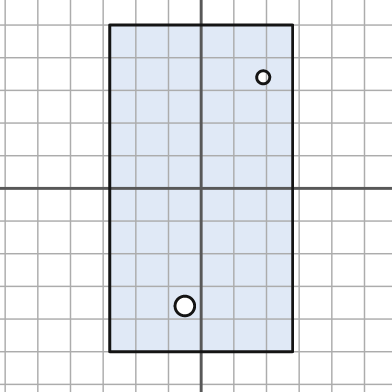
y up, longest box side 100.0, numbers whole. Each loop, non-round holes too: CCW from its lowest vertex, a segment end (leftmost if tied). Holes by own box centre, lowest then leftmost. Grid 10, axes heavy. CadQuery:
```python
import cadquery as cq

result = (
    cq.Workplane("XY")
    .moveTo(-28.0, -50.0)
    .lineTo(28.0, -50.0)
    .lineTo(28.0, 50.0)
    .lineTo(-28.0, 50.0)
    .close()
    .moveTo(-5.0, -36.0)
    .circle(3.0)
    .moveTo(19.0, 34.0)
    .circle(2.0)
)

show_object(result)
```